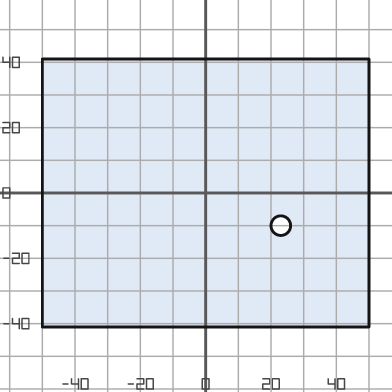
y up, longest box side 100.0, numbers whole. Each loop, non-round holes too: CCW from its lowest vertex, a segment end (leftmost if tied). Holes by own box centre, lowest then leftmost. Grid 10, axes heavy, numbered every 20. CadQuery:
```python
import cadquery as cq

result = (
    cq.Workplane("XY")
    .moveTo(-50.0, -41.0)
    .lineTo(50.0, -41.0)
    .lineTo(50.0, 41.0)
    .lineTo(-50.0, 41.0)
    .close()
    .moveTo(23.0, -10.0)
    .circle(3.0)
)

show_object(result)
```